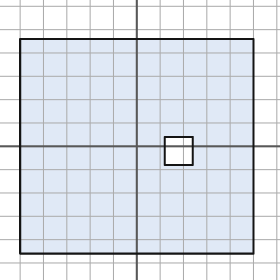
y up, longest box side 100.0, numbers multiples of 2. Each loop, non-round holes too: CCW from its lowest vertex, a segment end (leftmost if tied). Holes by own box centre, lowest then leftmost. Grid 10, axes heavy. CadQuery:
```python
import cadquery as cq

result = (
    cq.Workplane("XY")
    .moveTo(-50.0, -46.0)
    .lineTo(50.0, -46.0)
    .lineTo(50.0, 46.0)
    .lineTo(-50.0, 46.0)
    .close()
    .moveTo(12.0, -8.0)
    .lineTo(24.0, -8.0)
    .lineTo(24.0, 4.0)
    .lineTo(12.0, 4.0)
    .close()
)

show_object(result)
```